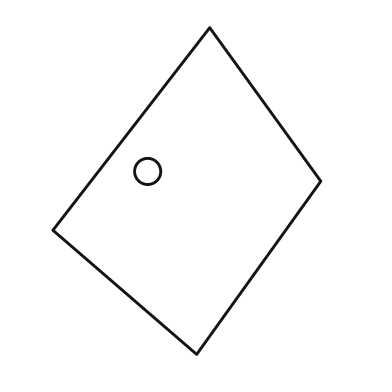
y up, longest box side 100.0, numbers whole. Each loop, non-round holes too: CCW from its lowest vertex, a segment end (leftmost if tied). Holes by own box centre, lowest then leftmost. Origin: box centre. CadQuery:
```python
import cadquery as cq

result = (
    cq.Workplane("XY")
    .moveTo(3.0, -50.0)
    .lineTo(41.0, 3.0)
    .lineTo(7.0, 50.0)
    .lineTo(-41.0, -12.0)
    .close()
    .moveTo(-12.0, 6.0)
    .circle(4.0)
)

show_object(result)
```